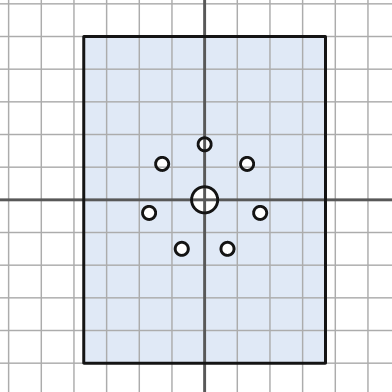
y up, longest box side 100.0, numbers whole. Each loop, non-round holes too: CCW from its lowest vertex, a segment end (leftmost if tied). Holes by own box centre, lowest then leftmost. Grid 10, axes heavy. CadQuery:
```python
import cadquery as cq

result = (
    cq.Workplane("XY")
    .moveTo(-37.0, -50.0)
    .lineTo(37.0, -50.0)
    .lineTo(37.0, 50.0)
    .lineTo(-37.0, 50.0)
    .close()
    .moveTo(-7.0, -15.0)
    .circle(2.0)
    .moveTo(7.0, -15.0)
    .circle(2.0)
    .moveTo(-17.0, -4.0)
    .circle(2.0)
    .moveTo(17.0, -4.0)
    .circle(2.0)
    .moveTo(0.0, 0.0)
    .circle(4.0)
    .moveTo(-13.0, 11.0)
    .circle(2.0)
    .moveTo(13.0, 11.0)
    .circle(2.0)
    .moveTo(0.0, 17.0)
    .circle(2.0)
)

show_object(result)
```